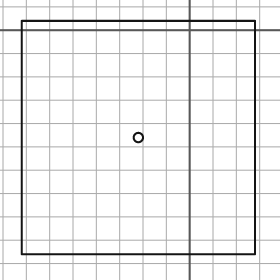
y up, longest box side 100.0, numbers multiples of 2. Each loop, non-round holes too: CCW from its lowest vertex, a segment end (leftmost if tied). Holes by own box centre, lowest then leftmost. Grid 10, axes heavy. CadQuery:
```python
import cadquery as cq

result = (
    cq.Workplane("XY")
    .moveTo(-72.0, -96.0)
    .lineTo(28.0, -96.0)
    .lineTo(28.0, 4.0)
    .lineTo(-72.0, 4.0)
    .close()
    .moveTo(-22.0, -46.0)
    .circle(2.0)
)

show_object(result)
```